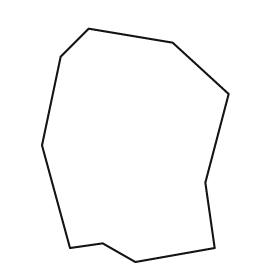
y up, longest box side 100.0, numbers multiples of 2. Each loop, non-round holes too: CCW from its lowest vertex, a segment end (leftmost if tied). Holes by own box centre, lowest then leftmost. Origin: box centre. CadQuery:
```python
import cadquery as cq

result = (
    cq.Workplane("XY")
    .moveTo(0.0, -50.0)
    .lineTo(34.0, -44.0)
    .lineTo(30.0, -16.0)
    .lineTo(40.0, 22.0)
    .lineTo(16.0, 44.0)
    .lineTo(-20.0, 50.0)
    .lineTo(-32.0, 38.0)
    .lineTo(-40.0, 0.0)
    .lineTo(-28.0, -44.0)
    .lineTo(-14.0, -42.0)
    .close()
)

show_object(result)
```